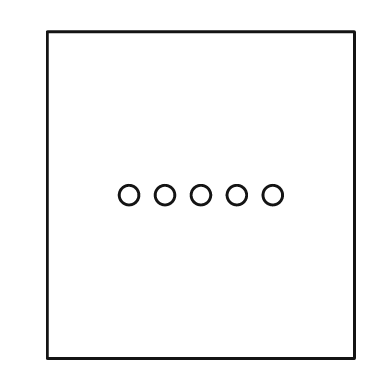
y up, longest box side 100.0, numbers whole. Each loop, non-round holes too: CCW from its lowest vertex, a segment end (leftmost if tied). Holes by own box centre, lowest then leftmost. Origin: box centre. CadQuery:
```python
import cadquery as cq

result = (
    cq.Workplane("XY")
    .moveTo(-47.0, -50.0)
    .lineTo(47.0, -50.0)
    .lineTo(47.0, 50.0)
    .lineTo(-47.0, 50.0)
    .close()
    .moveTo(-22.0, 0.0)
    .circle(3.0)
    .moveTo(-11.0, 0.0)
    .circle(3.0)
    .moveTo(0.0, 0.0)
    .circle(3.0)
    .moveTo(11.0, 0.0)
    .circle(3.0)
    .moveTo(22.0, 0.0)
    .circle(3.0)
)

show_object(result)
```